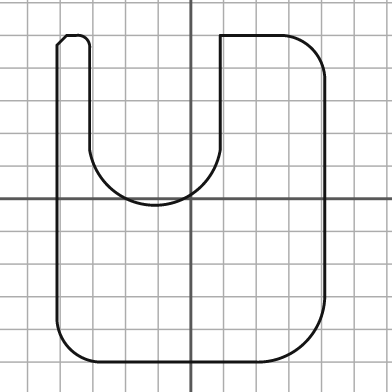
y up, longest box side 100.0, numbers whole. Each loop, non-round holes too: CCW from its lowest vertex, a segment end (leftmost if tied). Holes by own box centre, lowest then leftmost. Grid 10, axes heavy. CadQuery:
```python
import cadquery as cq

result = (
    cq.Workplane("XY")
    .moveTo(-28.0, -50.0)
    .lineTo(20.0, -50.0)
    .threePointArc((35.0, -44.0), (41.0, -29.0))
    .lineTo(41.0, 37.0)
    .threePointArc((37.0, 46.0), (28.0, 50.0))
    .lineTo(9.0, 50.0)
    .lineTo(9.0, 15.0)
    .threePointArc((-11.0, -2.0), (-31.0, 15.0))
    .lineTo(-31.0, 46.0)
    .threePointArc((-32.0, 49.0), (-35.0, 50.0))
    .lineTo(-38.0, 50.0)
    .lineTo(-41.0, 47.0)
    .lineTo(-41.0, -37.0)
    .threePointArc((-37.0, -46.0), (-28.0, -50.0))
    .close()
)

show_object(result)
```